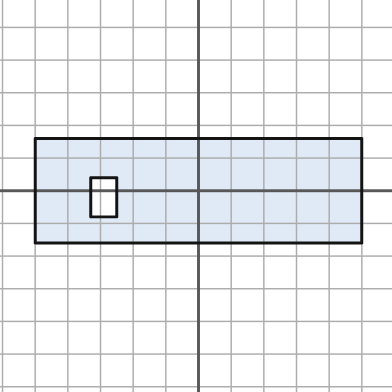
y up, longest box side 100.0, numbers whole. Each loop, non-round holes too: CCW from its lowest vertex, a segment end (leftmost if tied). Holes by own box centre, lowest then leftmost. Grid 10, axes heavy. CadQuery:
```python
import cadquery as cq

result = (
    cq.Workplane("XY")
    .moveTo(-50.0, -16.0)
    .lineTo(50.0, -16.0)
    .lineTo(50.0, 16.0)
    .lineTo(-50.0, 16.0)
    .close()
    .moveTo(-33.0, -8.0)
    .lineTo(-25.0, -8.0)
    .lineTo(-25.0, 4.0)
    .lineTo(-33.0, 4.0)
    .close()
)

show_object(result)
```